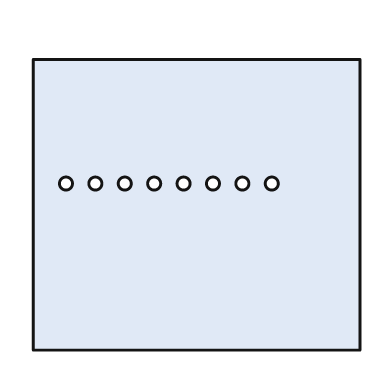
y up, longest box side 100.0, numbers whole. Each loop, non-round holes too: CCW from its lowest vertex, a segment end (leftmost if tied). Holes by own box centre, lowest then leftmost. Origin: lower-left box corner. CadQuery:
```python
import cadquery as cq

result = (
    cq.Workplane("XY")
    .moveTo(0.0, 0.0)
    .lineTo(100.0, 0.0)
    .lineTo(100.0, 89.0)
    .lineTo(0.0, 89.0)
    .close()
    .moveTo(10.0, 51.0)
    .circle(2.0)
    .moveTo(19.0, 51.0)
    .circle(2.0)
    .moveTo(28.0, 51.0)
    .circle(2.0)
    .moveTo(37.0, 51.0)
    .circle(2.0)
    .moveTo(46.0, 51.0)
    .circle(2.0)
    .moveTo(55.0, 51.0)
    .circle(2.0)
    .moveTo(64.0, 51.0)
    .circle(2.0)
    .moveTo(73.0, 51.0)
    .circle(2.0)
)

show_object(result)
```